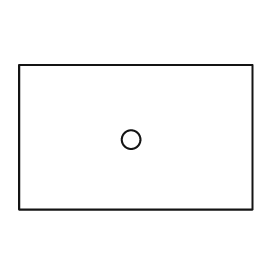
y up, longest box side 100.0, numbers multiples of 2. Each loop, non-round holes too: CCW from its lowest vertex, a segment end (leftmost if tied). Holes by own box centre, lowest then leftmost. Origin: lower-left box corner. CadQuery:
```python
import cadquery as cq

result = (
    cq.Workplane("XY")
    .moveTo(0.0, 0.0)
    .lineTo(100.0, 0.0)
    .lineTo(100.0, 62.0)
    .lineTo(0.0, 62.0)
    .close()
    .moveTo(48.0, 30.0)
    .circle(4.0)
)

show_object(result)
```